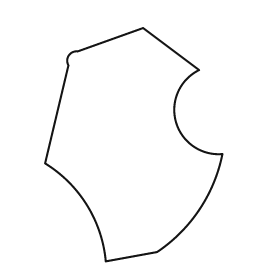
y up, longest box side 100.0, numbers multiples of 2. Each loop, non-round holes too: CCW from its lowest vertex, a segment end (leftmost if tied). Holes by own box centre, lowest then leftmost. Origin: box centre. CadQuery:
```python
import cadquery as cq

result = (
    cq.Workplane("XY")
    .moveTo(-12.0, -50.0)
    .lineTo(10.0, -46.0)
    .threePointArc((28.0, -28.0), (38.0, -4.0))
    .threePointArc((18.0, 10.0), (28.0, 32.0))
    .lineTo(4.0, 50.0)
    .lineTo(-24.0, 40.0)
    .threePointArc((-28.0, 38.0), (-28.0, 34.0))
    .lineTo(-38.0, -8.0)
    .threePointArc((-20.0, -26.0), (-12.0, -50.0))
    .close()
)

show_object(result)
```